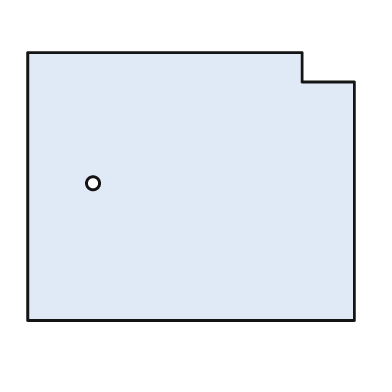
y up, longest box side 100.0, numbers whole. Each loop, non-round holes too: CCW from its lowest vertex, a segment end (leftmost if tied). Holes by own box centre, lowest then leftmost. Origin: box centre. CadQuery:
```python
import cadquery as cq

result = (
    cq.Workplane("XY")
    .moveTo(-50.0, -41.0)
    .lineTo(50.0, -41.0)
    .lineTo(50.0, 32.0)
    .lineTo(34.0, 32.0)
    .lineTo(34.0, 41.0)
    .lineTo(-50.0, 41.0)
    .close()
    .moveTo(-30.0, 1.0)
    .circle(2.0)
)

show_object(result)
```